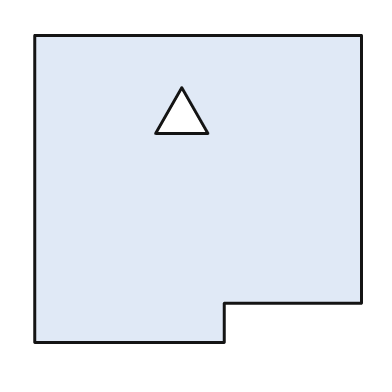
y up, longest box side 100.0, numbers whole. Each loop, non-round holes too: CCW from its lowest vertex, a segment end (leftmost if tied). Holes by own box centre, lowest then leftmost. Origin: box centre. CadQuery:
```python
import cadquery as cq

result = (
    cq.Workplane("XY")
    .moveTo(-50.0, -47.0)
    .lineTo(8.0, -47.0)
    .lineTo(8.0, -35.0)
    .lineTo(50.0, -35.0)
    .lineTo(50.0, 47.0)
    .lineTo(-50.0, 47.0)
    .close()
    .moveTo(-13.0, 17.0)
    .lineTo(3.0, 17.0)
    .lineTo(-5.0, 31.0)
    .close()
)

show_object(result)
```